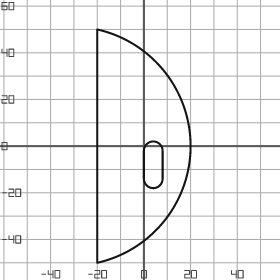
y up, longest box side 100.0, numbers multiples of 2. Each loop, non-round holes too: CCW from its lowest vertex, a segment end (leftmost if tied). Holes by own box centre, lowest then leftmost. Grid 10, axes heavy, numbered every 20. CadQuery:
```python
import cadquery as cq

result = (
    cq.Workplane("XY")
    .moveTo(-20.0, -50.0)
    .threePointArc((20.0, 0.0), (-20.0, 50.0))
    .close()
    .moveTo(0.0, -14.0)
    .threePointArc((4.0, -18.0), (8.0, -14.0))
    .lineTo(8.0, -2.0)
    .threePointArc((4.0, 2.0), (0.0, -2.0))
    .close()
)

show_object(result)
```